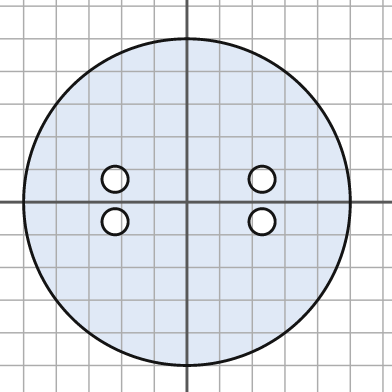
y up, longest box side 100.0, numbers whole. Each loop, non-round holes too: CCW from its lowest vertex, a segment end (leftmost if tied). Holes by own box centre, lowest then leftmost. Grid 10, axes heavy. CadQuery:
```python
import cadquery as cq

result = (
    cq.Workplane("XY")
    .moveTo(0.0, 0.0)
    .circle(50.0)
    .moveTo(-22.0, -6.0)
    .circle(4.0)
    .moveTo(23.0, -6.0)
    .circle(4.0)
    .moveTo(-22.0, 7.0)
    .circle(4.0)
    .moveTo(23.0, 7.0)
    .circle(4.0)
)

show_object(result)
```